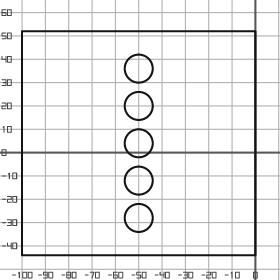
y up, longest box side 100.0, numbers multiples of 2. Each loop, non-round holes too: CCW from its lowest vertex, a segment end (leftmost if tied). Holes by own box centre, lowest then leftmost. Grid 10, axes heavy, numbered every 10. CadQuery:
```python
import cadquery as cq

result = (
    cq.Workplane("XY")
    .moveTo(-100.0, -44.0)
    .lineTo(0.0, -44.0)
    .lineTo(0.0, 52.0)
    .lineTo(-100.0, 52.0)
    .close()
    .moveTo(-50.0, -28.0)
    .circle(6.0)
    .moveTo(-50.0, -12.0)
    .circle(6.0)
    .moveTo(-50.0, 4.0)
    .circle(6.0)
    .moveTo(-50.0, 20.0)
    .circle(6.0)
    .moveTo(-50.0, 36.0)
    .circle(6.0)
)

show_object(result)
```